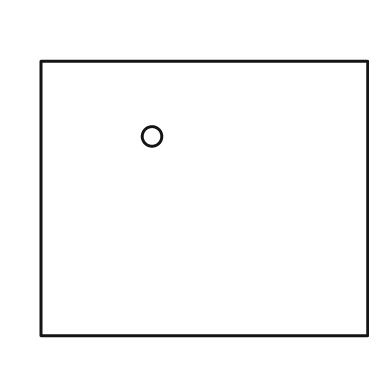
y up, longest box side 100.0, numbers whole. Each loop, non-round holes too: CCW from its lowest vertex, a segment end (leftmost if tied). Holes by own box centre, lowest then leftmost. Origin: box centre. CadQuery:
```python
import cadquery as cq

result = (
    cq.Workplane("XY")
    .moveTo(-50.0, -42.0)
    .lineTo(50.0, -42.0)
    .lineTo(50.0, 42.0)
    .lineTo(-50.0, 42.0)
    .close()
    .moveTo(-16.0, 19.0)
    .circle(3.0)
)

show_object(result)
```